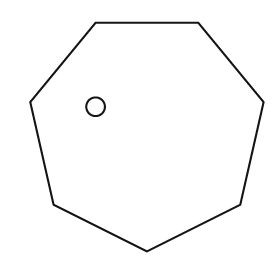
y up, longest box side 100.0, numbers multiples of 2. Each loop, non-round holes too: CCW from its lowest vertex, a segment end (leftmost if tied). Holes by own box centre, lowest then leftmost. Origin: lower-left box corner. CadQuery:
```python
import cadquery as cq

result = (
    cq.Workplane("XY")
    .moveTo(50.0, 0.0)
    .lineTo(90.0, 20.0)
    .lineTo(100.0, 64.0)
    .lineTo(72.0, 98.0)
    .lineTo(28.0, 98.0)
    .lineTo(0.0, 64.0)
    .lineTo(10.0, 20.0)
    .close()
    .moveTo(28.0, 62.0)
    .circle(4.0)
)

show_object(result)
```